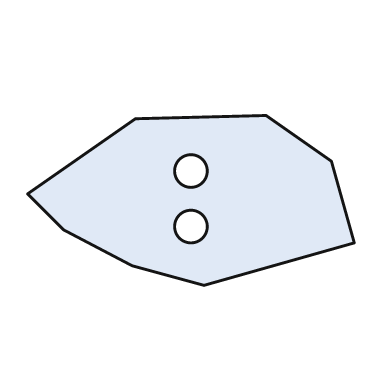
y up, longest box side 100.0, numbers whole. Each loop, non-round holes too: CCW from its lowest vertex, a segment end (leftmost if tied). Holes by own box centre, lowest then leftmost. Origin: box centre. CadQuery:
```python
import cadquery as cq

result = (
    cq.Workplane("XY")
    .moveTo(4.0, -26.0)
    .lineTo(50.0, -13.0)
    .lineTo(43.0, 12.0)
    .lineTo(23.0, 26.0)
    .lineTo(-17.0, 25.0)
    .lineTo(-50.0, 2.0)
    .lineTo(-39.0, -9.0)
    .lineTo(-18.0, -20.0)
    .close()
    .moveTo(0.0, -8.0)
    .circle(5.0)
    .moveTo(0.0, 9.0)
    .circle(5.0)
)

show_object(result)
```